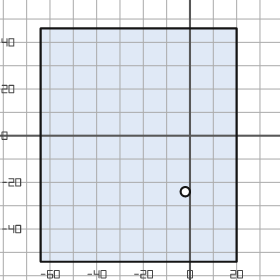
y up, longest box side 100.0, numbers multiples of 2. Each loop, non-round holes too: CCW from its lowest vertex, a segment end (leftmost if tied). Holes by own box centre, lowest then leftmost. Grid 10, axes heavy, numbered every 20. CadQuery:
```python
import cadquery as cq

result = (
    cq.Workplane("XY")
    .moveTo(-64.0, -54.0)
    .lineTo(20.0, -54.0)
    .lineTo(20.0, 46.0)
    .lineTo(-64.0, 46.0)
    .close()
    .moveTo(-2.0, -24.0)
    .circle(2.0)
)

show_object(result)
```